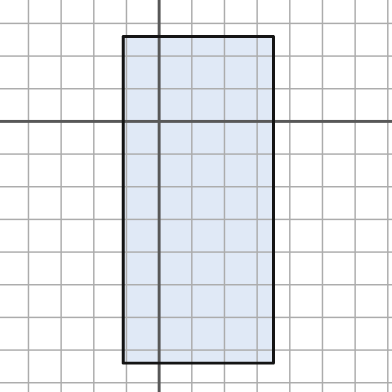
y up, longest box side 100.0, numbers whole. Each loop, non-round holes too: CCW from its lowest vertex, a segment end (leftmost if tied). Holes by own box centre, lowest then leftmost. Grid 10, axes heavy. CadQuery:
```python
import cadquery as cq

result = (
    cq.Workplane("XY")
    .moveTo(-11.0, -74.0)
    .lineTo(35.0, -74.0)
    .lineTo(35.0, 26.0)
    .lineTo(-11.0, 26.0)
    .close()
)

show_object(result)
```